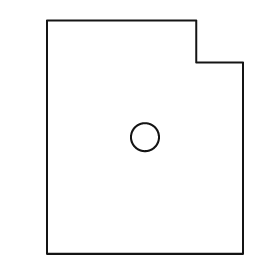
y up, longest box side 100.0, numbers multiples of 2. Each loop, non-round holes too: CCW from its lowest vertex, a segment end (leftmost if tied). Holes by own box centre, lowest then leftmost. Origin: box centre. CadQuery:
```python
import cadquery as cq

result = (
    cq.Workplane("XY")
    .moveTo(-42.0, -50.0)
    .lineTo(42.0, -50.0)
    .lineTo(42.0, 32.0)
    .lineTo(22.0, 32.0)
    .lineTo(22.0, 50.0)
    .lineTo(-42.0, 50.0)
    .close()
    .moveTo(0.0, 0.0)
    .circle(6.0)
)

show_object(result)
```